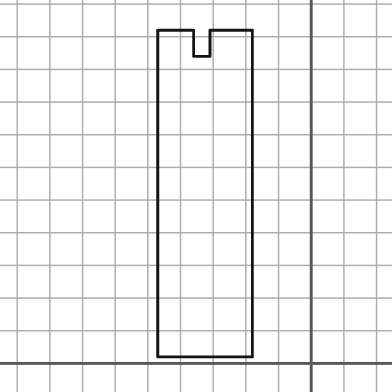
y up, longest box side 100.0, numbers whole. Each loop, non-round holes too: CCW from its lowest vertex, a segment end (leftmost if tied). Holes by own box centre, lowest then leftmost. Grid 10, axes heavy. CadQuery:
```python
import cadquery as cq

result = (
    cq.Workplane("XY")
    .moveTo(-47.0, 2.0)
    .lineTo(-18.0, 2.0)
    .lineTo(-18.0, 102.0)
    .lineTo(-31.0, 102.0)
    .lineTo(-31.0, 94.0)
    .lineTo(-36.0, 94.0)
    .lineTo(-36.0, 102.0)
    .lineTo(-47.0, 102.0)
    .close()
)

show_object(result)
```